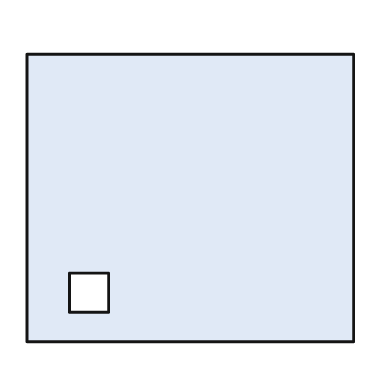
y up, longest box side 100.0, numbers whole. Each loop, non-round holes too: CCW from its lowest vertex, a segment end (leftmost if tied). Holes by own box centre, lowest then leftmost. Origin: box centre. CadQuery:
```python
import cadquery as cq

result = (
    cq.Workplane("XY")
    .moveTo(-50.0, -44.0)
    .lineTo(50.0, -44.0)
    .lineTo(50.0, 44.0)
    .lineTo(-50.0, 44.0)
    .close()
    .moveTo(-37.0, -35.0)
    .lineTo(-25.0, -35.0)
    .lineTo(-25.0, -23.0)
    .lineTo(-37.0, -23.0)
    .close()
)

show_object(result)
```